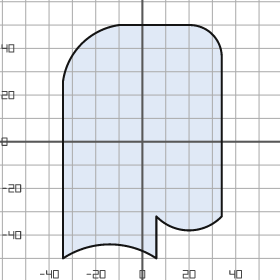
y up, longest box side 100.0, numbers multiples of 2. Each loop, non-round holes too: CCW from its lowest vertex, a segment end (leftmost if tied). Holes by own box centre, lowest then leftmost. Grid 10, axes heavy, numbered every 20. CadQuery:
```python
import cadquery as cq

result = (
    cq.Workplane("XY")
    .moveTo(-34.0, -50.0)
    .threePointArc((-14.0, -44.0), (6.0, -50.0))
    .lineTo(6.0, -32.0)
    .threePointArc((20.0, -38.0), (34.0, -32.0))
    .lineTo(34.0, 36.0)
    .threePointArc((30.0, 46.0), (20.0, 50.0))
    .lineTo(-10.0, 50.0)
    .threePointArc((-26.0, 42.0), (-34.0, 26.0))
    .close()
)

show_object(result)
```